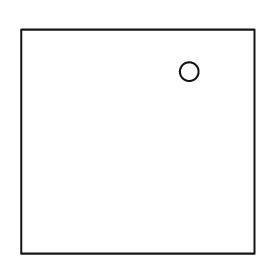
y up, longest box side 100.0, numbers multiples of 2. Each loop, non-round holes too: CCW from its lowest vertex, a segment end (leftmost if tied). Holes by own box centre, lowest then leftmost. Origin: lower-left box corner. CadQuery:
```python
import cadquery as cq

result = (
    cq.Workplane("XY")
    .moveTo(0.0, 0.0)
    .lineTo(100.0, 0.0)
    .lineTo(100.0, 96.0)
    .lineTo(0.0, 96.0)
    .close()
    .moveTo(72.0, 78.0)
    .circle(4.0)
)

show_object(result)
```